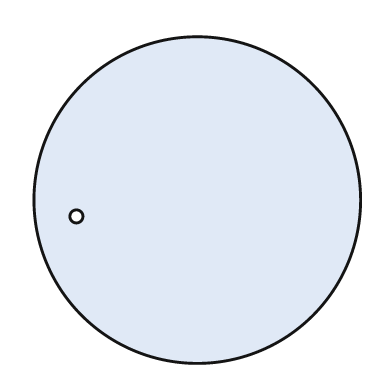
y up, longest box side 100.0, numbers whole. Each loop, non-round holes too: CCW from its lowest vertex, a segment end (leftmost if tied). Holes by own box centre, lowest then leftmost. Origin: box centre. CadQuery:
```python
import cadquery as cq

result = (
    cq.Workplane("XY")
    .moveTo(0.0, 0.0)
    .circle(50.0)
    .moveTo(-37.0, -5.0)
    .circle(2.0)
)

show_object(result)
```